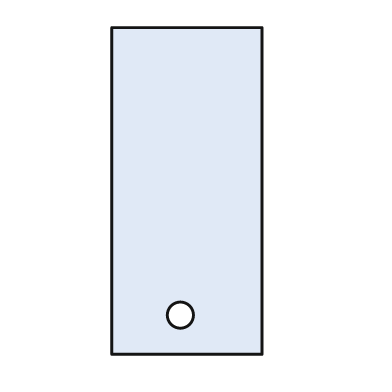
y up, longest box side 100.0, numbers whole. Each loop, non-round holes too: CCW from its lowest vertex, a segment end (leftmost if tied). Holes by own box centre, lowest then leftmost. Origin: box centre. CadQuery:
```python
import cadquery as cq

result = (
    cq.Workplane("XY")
    .moveTo(-23.0, -50.0)
    .lineTo(23.0, -50.0)
    .lineTo(23.0, 50.0)
    .lineTo(-23.0, 50.0)
    .close()
    .moveTo(-2.0, -38.0)
    .circle(4.0)
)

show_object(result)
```